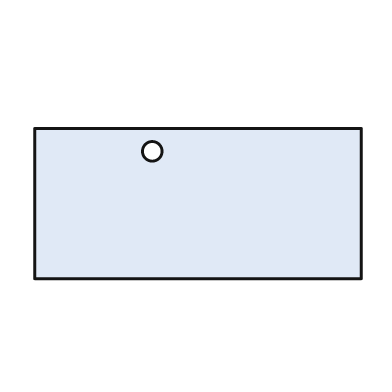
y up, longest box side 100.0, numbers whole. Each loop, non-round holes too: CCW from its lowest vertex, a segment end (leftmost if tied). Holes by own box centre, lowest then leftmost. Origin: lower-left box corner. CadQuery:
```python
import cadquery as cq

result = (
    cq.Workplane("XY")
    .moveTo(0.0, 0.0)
    .lineTo(100.0, 0.0)
    .lineTo(100.0, 46.0)
    .lineTo(0.0, 46.0)
    .close()
    .moveTo(36.0, 39.0)
    .circle(3.0)
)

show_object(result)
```